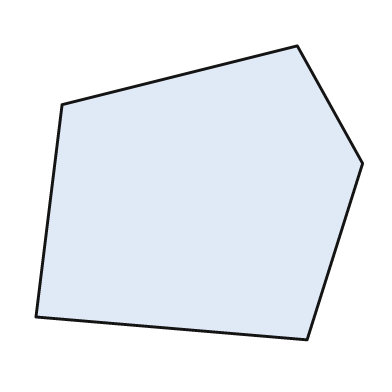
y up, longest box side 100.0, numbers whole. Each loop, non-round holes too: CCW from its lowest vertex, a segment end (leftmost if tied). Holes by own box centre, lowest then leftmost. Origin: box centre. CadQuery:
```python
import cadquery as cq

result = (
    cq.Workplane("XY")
    .moveTo(33.0, -45.0)
    .lineTo(50.0, 9.0)
    .lineTo(30.0, 45.0)
    .lineTo(-42.0, 27.0)
    .lineTo(-50.0, -38.0)
    .close()
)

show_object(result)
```